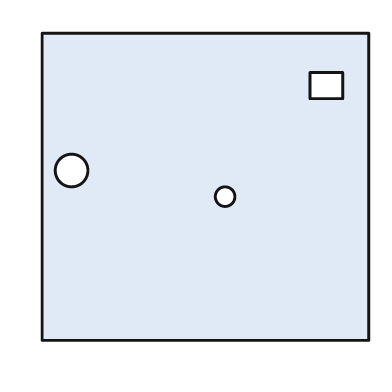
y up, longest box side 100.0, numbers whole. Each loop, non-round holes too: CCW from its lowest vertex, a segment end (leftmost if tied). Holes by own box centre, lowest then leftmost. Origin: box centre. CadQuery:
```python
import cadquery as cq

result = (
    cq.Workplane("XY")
    .moveTo(-50.0, -47.0)
    .lineTo(50.0, -47.0)
    .lineTo(50.0, 47.0)
    .lineTo(-50.0, 47.0)
    .close()
    .moveTo(6.0, -3.0)
    .circle(3.0)
    .moveTo(-41.0, 5.0)
    .circle(5.0)
    .moveTo(32.0, 27.0)
    .lineTo(42.0, 27.0)
    .lineTo(42.0, 35.0)
    .lineTo(32.0, 35.0)
    .close()
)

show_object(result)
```